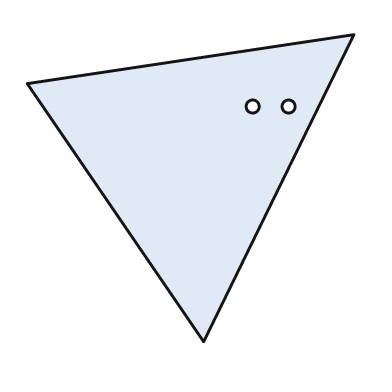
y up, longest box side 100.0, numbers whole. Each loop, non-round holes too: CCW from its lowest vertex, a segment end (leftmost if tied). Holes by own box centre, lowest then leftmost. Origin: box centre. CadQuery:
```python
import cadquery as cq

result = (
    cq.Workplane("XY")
    .moveTo(4.0, -47.0)
    .lineTo(50.0, 47.0)
    .lineTo(-50.0, 32.0)
    .close()
    .moveTo(19.0, 25.0)
    .circle(2.0)
    .moveTo(30.0, 25.0)
    .circle(2.0)
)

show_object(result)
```